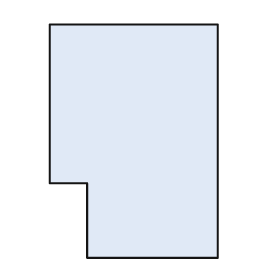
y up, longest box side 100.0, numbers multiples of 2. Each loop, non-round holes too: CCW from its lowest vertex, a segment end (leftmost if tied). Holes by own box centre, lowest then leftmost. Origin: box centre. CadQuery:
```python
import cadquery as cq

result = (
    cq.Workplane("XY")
    .moveTo(-20.0, -50.0)
    .lineTo(36.0, -50.0)
    .lineTo(36.0, 50.0)
    .lineTo(-36.0, 50.0)
    .lineTo(-36.0, -18.0)
    .lineTo(-20.0, -18.0)
    .close()
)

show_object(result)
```